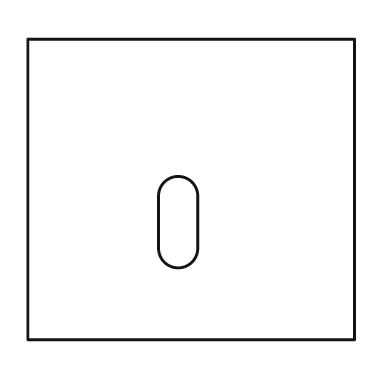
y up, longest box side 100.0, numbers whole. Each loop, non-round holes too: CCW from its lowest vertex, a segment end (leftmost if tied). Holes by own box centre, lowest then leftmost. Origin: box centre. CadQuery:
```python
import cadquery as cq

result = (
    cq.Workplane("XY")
    .moveTo(-50.0, -46.0)
    .lineTo(50.0, -46.0)
    .lineTo(50.0, 46.0)
    .lineTo(-50.0, 46.0)
    .close()
    .moveTo(-10.0, -18.0)
    .threePointArc((-4.0, -24.0), (2.0, -18.0))
    .lineTo(2.0, -2.0)
    .threePointArc((-4.0, 4.0), (-10.0, -2.0))
    .close()
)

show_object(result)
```